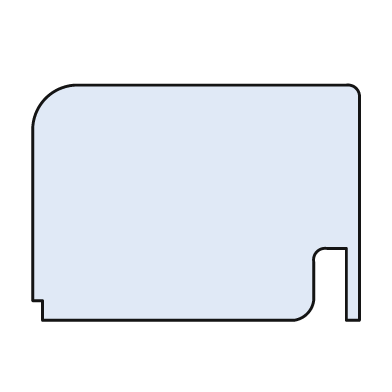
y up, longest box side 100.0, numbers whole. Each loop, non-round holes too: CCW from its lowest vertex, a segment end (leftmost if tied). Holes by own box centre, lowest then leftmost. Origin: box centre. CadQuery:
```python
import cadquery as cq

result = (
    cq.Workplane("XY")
    .moveTo(-47.0, -36.0)
    .lineTo(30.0, -36.0)
    .threePointArc((34.0, -34.0), (36.0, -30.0))
    .lineTo(36.0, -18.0)
    .threePointArc((37.0, -15.0), (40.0, -14.0))
    .lineTo(46.0, -14.0)
    .lineTo(46.0, -36.0)
    .lineTo(50.0, -36.0)
    .lineTo(50.0, 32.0)
    .threePointArc((49.0, 35.0), (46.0, 36.0))
    .lineTo(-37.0, 36.0)
    .threePointArc((-46.0, 32.0), (-50.0, 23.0))
    .lineTo(-50.0, -30.0)
    .lineTo(-47.0, -30.0)
    .close()
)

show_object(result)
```